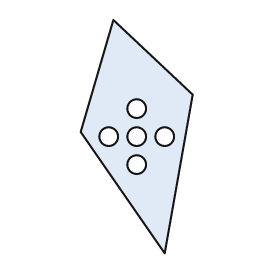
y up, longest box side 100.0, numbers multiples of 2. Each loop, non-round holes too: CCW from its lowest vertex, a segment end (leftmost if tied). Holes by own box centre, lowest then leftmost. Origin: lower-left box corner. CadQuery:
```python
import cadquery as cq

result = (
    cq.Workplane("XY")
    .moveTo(36.0, 0.0)
    .lineTo(48.0, 68.0)
    .lineTo(14.0, 100.0)
    .lineTo(0.0, 52.0)
    .close()
    .moveTo(24.0, 38.0)
    .circle(4.0)
    .moveTo(12.0, 50.0)
    .circle(4.0)
    .moveTo(24.0, 50.0)
    .circle(4.0)
    .moveTo(36.0, 50.0)
    .circle(4.0)
    .moveTo(24.0, 62.0)
    .circle(4.0)
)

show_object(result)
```